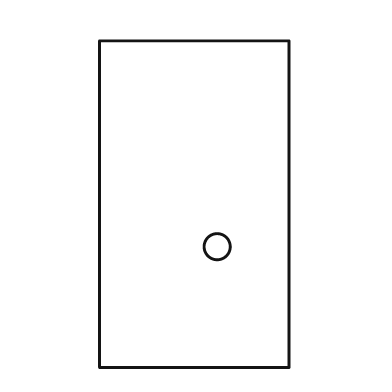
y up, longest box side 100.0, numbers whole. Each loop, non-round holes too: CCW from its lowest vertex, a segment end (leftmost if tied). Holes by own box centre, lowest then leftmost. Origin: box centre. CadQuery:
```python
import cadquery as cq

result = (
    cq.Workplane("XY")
    .moveTo(-29.0, -50.0)
    .lineTo(29.0, -50.0)
    .lineTo(29.0, 50.0)
    .lineTo(-29.0, 50.0)
    .close()
    .moveTo(7.0, -13.0)
    .circle(4.0)
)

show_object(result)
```